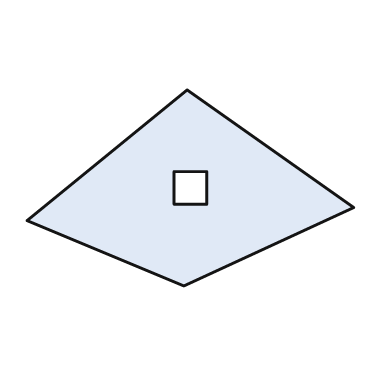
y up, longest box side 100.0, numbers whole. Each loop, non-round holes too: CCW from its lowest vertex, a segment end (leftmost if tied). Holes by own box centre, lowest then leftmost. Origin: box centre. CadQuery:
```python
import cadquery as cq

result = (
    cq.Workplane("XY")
    .moveTo(-2.0, -30.0)
    .lineTo(50.0, -6.0)
    .lineTo(-1.0, 30.0)
    .lineTo(-50.0, -10.0)
    .close()
    .moveTo(-5.0, -5.0)
    .lineTo(5.0, -5.0)
    .lineTo(5.0, 5.0)
    .lineTo(-5.0, 5.0)
    .close()
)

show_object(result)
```